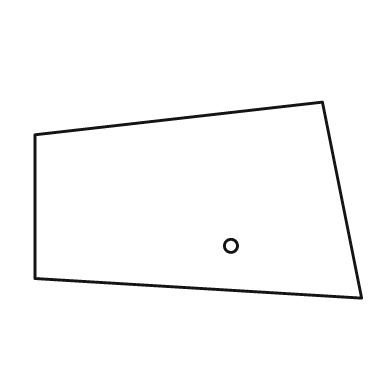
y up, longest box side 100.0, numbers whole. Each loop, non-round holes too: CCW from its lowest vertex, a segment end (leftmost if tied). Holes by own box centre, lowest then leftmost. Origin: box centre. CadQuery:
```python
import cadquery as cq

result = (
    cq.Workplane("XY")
    .moveTo(50.0, -30.0)
    .lineTo(38.0, 30.0)
    .lineTo(-50.0, 20.0)
    .lineTo(-50.0, -24.0)
    .close()
    .moveTo(10.0, -14.0)
    .circle(2.0)
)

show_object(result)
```